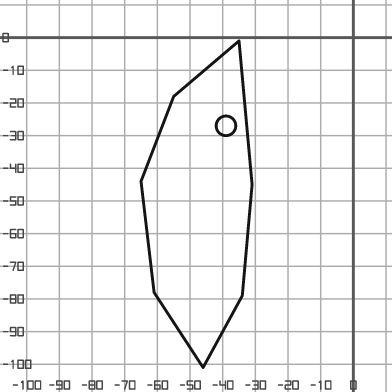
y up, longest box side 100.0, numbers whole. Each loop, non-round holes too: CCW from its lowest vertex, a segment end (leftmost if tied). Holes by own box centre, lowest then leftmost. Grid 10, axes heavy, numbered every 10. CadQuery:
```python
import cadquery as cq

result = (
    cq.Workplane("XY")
    .moveTo(-46.0, -101.0)
    .lineTo(-34.0, -79.0)
    .lineTo(-31.0, -45.0)
    .lineTo(-35.0, -1.0)
    .lineTo(-55.0, -18.0)
    .lineTo(-65.0, -44.0)
    .lineTo(-61.0, -78.0)
    .close()
    .moveTo(-39.0, -27.0)
    .circle(3.0)
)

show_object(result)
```